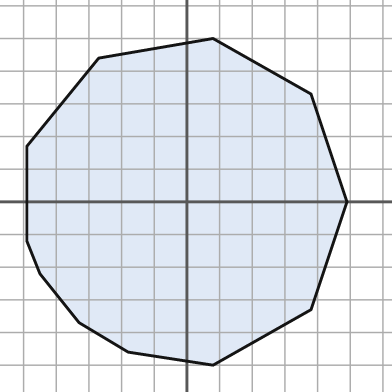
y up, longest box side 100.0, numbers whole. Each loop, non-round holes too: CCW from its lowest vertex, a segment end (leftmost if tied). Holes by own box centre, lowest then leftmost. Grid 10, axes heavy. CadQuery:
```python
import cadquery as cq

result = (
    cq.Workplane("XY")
    .moveTo(8.0, -50.0)
    .lineTo(38.0, -33.0)
    .lineTo(49.0, 0.0)
    .lineTo(38.0, 33.0)
    .lineTo(8.0, 50.0)
    .lineTo(-27.0, 44.0)
    .lineTo(-49.0, 17.0)
    .lineTo(-49.0, -12.0)
    .lineTo(-45.0, -22.0)
    .lineTo(-33.0, -37.0)
    .lineTo(-18.0, -46.0)
    .close()
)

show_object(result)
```